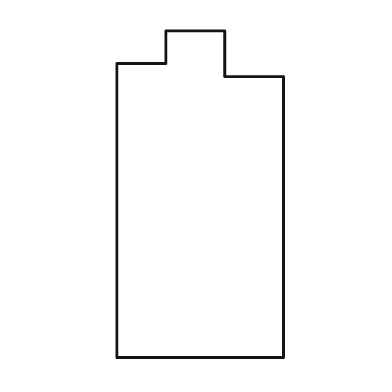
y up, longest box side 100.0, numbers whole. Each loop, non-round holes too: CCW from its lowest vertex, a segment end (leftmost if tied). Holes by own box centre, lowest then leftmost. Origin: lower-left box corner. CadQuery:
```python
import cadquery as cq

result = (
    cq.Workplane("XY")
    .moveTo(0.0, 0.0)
    .lineTo(51.0, 0.0)
    .lineTo(51.0, 86.0)
    .lineTo(33.0, 86.0)
    .lineTo(33.0, 100.0)
    .lineTo(15.0, 100.0)
    .lineTo(15.0, 90.0)
    .lineTo(0.0, 90.0)
    .close()
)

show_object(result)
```